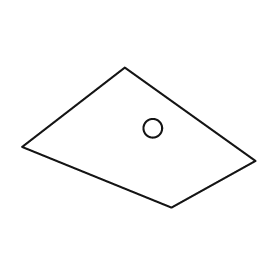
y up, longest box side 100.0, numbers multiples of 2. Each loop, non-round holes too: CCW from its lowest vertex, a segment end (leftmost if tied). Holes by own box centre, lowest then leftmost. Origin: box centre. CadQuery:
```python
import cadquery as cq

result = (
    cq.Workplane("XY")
    .moveTo(14.0, -30.0)
    .lineTo(50.0, -10.0)
    .lineTo(-6.0, 30.0)
    .lineTo(-50.0, -4.0)
    .close()
    .moveTo(6.0, 4.0)
    .circle(4.0)
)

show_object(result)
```